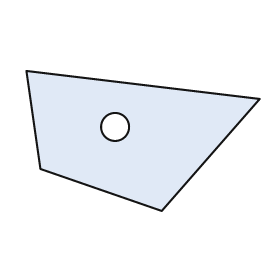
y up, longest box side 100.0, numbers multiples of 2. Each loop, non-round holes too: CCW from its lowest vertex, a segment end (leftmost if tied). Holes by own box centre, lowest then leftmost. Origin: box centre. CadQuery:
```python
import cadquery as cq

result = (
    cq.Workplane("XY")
    .moveTo(8.0, -30.0)
    .lineTo(50.0, 18.0)
    .lineTo(-50.0, 30.0)
    .lineTo(-44.0, -12.0)
    .close()
    .moveTo(-12.0, 6.0)
    .circle(6.0)
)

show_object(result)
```